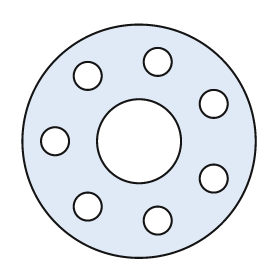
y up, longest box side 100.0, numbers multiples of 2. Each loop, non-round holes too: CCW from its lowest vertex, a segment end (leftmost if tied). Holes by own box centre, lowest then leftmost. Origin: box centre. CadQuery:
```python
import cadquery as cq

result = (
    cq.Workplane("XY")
    .moveTo(0.0, 0.0)
    .circle(50.0)
    .moveTo(8.0, -34.0)
    .circle(6.0)
    .moveTo(-22.0, -28.0)
    .circle(6.0)
    .moveTo(32.0, -16.0)
    .circle(6.0)
    .moveTo(-36.0, 0.0)
    .circle(6.0)
    .moveTo(0.0, 0.0)
    .circle(18.0)
    .moveTo(32.0, 16.0)
    .circle(6.0)
    .moveTo(-22.0, 28.0)
    .circle(6.0)
    .moveTo(8.0, 34.0)
    .circle(6.0)
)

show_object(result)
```